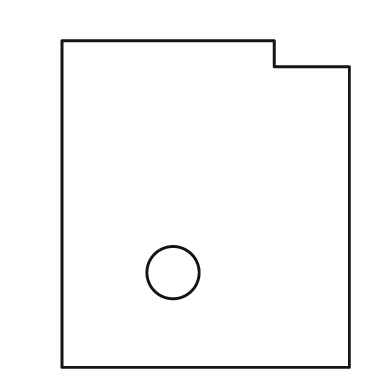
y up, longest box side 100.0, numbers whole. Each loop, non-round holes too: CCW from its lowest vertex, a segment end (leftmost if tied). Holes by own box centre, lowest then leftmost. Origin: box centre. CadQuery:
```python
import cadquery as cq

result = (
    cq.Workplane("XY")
    .moveTo(-44.0, -50.0)
    .lineTo(44.0, -50.0)
    .lineTo(44.0, 42.0)
    .lineTo(21.0, 42.0)
    .lineTo(21.0, 50.0)
    .lineTo(-44.0, 50.0)
    .close()
    .moveTo(-10.0, -21.0)
    .circle(8.0)
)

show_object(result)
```